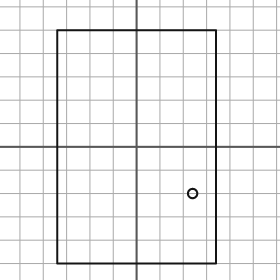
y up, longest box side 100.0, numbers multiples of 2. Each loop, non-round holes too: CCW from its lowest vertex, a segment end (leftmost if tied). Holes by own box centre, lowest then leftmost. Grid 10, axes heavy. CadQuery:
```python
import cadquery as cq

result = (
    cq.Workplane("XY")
    .moveTo(-34.0, -50.0)
    .lineTo(34.0, -50.0)
    .lineTo(34.0, 50.0)
    .lineTo(-34.0, 50.0)
    .close()
    .moveTo(24.0, -20.0)
    .circle(2.0)
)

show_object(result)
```